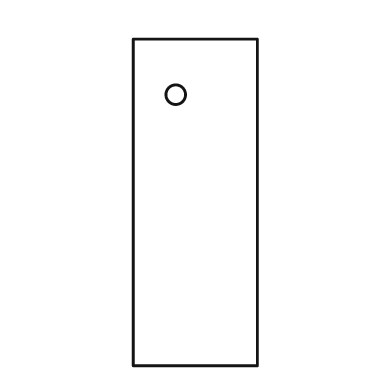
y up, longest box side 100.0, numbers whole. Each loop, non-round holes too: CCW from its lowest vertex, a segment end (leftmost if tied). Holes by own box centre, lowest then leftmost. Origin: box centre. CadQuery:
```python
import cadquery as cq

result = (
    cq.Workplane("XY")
    .moveTo(-19.0, -50.0)
    .lineTo(19.0, -50.0)
    .lineTo(19.0, 50.0)
    .lineTo(-19.0, 50.0)
    .close()
    .moveTo(-6.0, 33.0)
    .circle(3.0)
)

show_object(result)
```